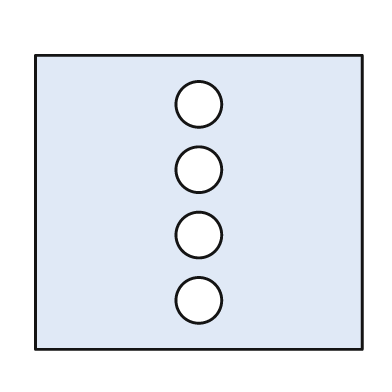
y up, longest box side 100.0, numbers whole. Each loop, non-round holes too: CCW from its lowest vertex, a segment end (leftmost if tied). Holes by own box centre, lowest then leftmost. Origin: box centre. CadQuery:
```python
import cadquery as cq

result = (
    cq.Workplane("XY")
    .moveTo(-50.0, -45.0)
    .lineTo(50.0, -45.0)
    .lineTo(50.0, 45.0)
    .lineTo(-50.0, 45.0)
    .close()
    .moveTo(0.0, -30.0)
    .circle(7.0)
    .moveTo(0.0, -10.0)
    .circle(7.0)
    .moveTo(0.0, 10.0)
    .circle(7.0)
    .moveTo(0.0, 30.0)
    .circle(7.0)
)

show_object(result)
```